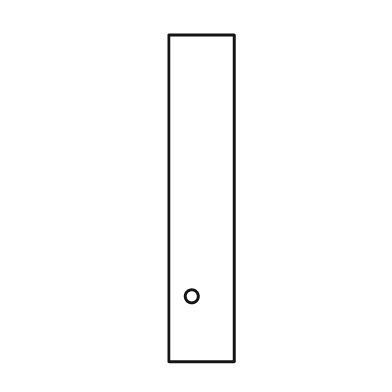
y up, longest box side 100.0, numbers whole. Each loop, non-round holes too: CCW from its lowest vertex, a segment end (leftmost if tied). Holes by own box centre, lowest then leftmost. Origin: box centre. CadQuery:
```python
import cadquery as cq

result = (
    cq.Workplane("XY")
    .moveTo(-10.0, -50.0)
    .lineTo(10.0, -50.0)
    .lineTo(10.0, 50.0)
    .lineTo(-10.0, 50.0)
    .close()
    .moveTo(-3.0, -30.0)
    .circle(2.0)
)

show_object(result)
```